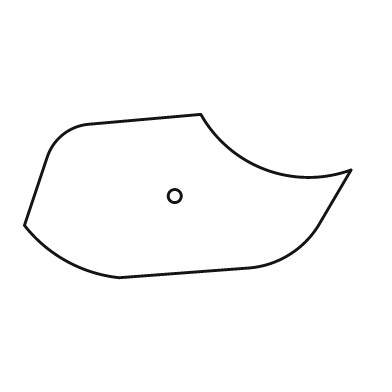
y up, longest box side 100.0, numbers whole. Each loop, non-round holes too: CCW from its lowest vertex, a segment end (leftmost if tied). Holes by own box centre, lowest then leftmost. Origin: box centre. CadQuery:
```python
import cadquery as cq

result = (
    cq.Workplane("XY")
    .moveTo(-21.0, -25.0)
    .lineTo(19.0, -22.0)
    .threePointArc((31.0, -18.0), (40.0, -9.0))
    .lineTo(50.0, 8.0)
    .threePointArc((24.0, 8.0), (4.0, 25.0))
    .lineTo(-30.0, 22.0)
    .threePointArc((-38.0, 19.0), (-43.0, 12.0))
    .lineTo(-50.0, -9.0)
    .threePointArc((-37.0, -20.0), (-21.0, -25.0))
    .close()
    .moveTo(-4.0, 0.0)
    .circle(2.0)
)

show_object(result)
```